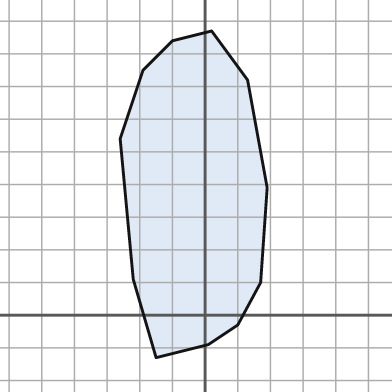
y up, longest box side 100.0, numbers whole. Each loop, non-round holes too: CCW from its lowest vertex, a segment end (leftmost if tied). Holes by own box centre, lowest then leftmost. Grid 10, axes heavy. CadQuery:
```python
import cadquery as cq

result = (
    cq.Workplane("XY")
    .moveTo(-15.0, -13.0)
    .lineTo(1.0, -9.0)
    .lineTo(10.0, -3.0)
    .lineTo(17.0, 10.0)
    .lineTo(19.0, 39.0)
    .lineTo(13.0, 72.0)
    .lineTo(2.0, 87.0)
    .lineTo(-10.0, 84.0)
    .lineTo(-19.0, 75.0)
    .lineTo(-26.0, 54.0)
    .lineTo(-22.0, 11.0)
    .close()
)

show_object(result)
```